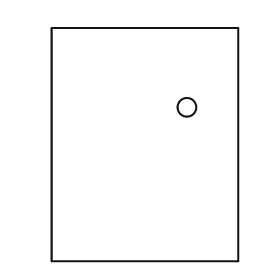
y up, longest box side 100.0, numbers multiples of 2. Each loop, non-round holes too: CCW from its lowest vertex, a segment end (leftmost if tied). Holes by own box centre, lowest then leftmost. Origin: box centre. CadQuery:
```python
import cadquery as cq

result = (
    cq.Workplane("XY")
    .moveTo(-40.0, -50.0)
    .lineTo(40.0, -50.0)
    .lineTo(40.0, 50.0)
    .lineTo(-40.0, 50.0)
    .close()
    .moveTo(18.0, 16.0)
    .circle(4.0)
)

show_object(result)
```